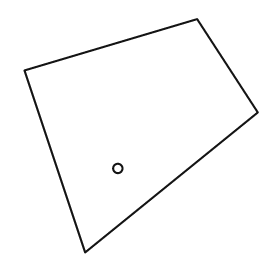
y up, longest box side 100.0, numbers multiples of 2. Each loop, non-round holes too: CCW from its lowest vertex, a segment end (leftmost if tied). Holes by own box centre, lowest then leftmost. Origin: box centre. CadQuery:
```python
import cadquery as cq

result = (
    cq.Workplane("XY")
    .moveTo(-24.0, -50.0)
    .lineTo(50.0, 10.0)
    .lineTo(24.0, 50.0)
    .lineTo(-50.0, 28.0)
    .close()
    .moveTo(-10.0, -14.0)
    .circle(2.0)
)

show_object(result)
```